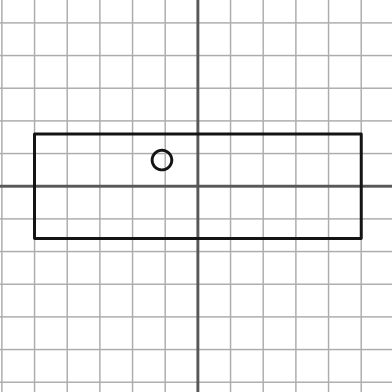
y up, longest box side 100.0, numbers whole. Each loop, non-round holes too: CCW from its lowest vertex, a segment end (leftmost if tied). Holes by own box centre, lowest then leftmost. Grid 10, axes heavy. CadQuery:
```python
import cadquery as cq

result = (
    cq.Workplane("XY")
    .moveTo(-50.0, -16.0)
    .lineTo(50.0, -16.0)
    .lineTo(50.0, 16.0)
    .lineTo(-50.0, 16.0)
    .close()
    .moveTo(-11.0, 8.0)
    .circle(3.0)
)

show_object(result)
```